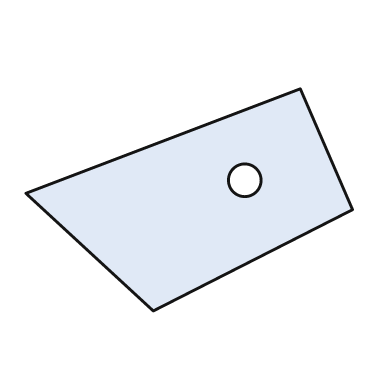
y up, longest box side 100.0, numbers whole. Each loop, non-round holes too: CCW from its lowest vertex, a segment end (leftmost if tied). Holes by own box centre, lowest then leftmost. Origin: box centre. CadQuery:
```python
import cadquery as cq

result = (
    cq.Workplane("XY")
    .moveTo(-11.0, -34.0)
    .lineTo(50.0, -3.0)
    .lineTo(34.0, 34.0)
    .lineTo(-50.0, 2.0)
    .close()
    .moveTo(17.0, 6.0)
    .circle(5.0)
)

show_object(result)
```